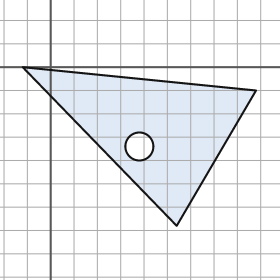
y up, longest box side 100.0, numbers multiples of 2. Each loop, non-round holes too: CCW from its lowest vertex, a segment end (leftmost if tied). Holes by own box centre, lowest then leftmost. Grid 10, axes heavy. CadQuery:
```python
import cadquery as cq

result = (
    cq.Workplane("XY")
    .moveTo(54.0, -68.0)
    .lineTo(88.0, -10.0)
    .lineTo(-12.0, 0.0)
    .close()
    .moveTo(38.0, -34.0)
    .circle(6.0)
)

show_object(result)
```